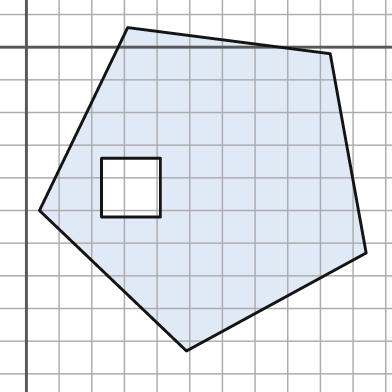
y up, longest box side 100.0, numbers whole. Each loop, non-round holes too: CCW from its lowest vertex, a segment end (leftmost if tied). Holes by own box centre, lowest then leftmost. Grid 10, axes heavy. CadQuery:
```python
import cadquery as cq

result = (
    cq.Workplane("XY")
    .moveTo(49.0, -93.0)
    .lineTo(104.0, -63.0)
    .lineTo(93.0, -2.0)
    .lineTo(31.0, 6.0)
    .lineTo(4.0, -50.0)
    .close()
    .moveTo(23.0, -52.0)
    .lineTo(41.0, -52.0)
    .lineTo(41.0, -34.0)
    .lineTo(23.0, -34.0)
    .close()
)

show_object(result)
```